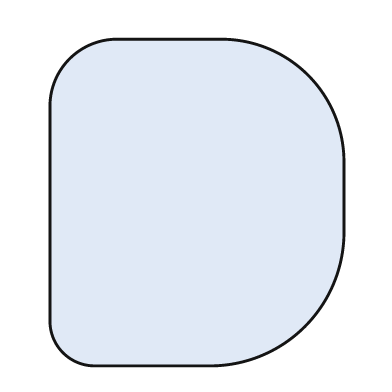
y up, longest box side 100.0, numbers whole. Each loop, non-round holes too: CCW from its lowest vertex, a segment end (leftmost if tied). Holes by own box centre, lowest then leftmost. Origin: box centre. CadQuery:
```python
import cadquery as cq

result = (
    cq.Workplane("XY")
    .moveTo(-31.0, -50.0)
    .lineTo(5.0, -50.0)
    .threePointArc((33.0, -38.0), (45.0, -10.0))
    .lineTo(45.0, 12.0)
    .threePointArc((34.0, 39.0), (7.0, 50.0))
    .lineTo(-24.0, 50.0)
    .threePointArc((-39.0, 44.0), (-45.0, 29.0))
    .lineTo(-45.0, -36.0)
    .threePointArc((-41.0, -46.0), (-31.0, -50.0))
    .close()
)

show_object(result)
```